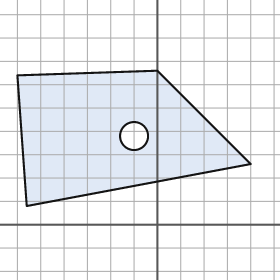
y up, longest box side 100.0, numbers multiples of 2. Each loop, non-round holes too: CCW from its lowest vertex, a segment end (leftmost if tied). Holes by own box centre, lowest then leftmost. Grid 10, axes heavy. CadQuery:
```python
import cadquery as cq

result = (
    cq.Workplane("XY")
    .moveTo(-56.0, 8.0)
    .lineTo(40.0, 26.0)
    .lineTo(0.0, 66.0)
    .lineTo(-60.0, 64.0)
    .close()
    .moveTo(-10.0, 38.0)
    .circle(6.0)
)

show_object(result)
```